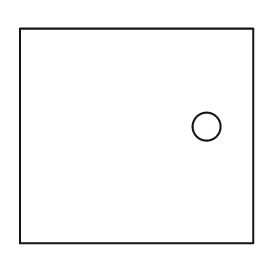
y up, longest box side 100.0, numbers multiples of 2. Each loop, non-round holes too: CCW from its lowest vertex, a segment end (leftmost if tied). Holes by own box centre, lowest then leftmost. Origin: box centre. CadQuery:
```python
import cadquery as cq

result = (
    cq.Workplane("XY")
    .moveTo(-50.0, -46.0)
    .lineTo(50.0, -46.0)
    .lineTo(50.0, 46.0)
    .lineTo(-50.0, 46.0)
    .close()
    .moveTo(30.0, 4.0)
    .circle(6.0)
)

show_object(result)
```